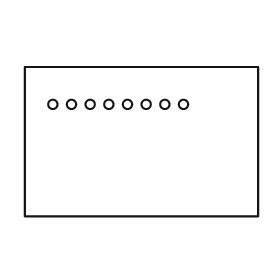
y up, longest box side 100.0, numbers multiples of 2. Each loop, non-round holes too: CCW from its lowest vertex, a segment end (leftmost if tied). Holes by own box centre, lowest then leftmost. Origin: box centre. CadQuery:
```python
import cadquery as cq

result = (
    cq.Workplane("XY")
    .moveTo(-50.0, -32.0)
    .lineTo(50.0, -32.0)
    .lineTo(50.0, 32.0)
    .lineTo(-50.0, 32.0)
    .close()
    .moveTo(-38.0, 16.0)
    .circle(2.0)
    .moveTo(-30.0, 16.0)
    .circle(2.0)
    .moveTo(-22.0, 16.0)
    .circle(2.0)
    .moveTo(-14.0, 16.0)
    .circle(2.0)
    .moveTo(-6.0, 16.0)
    .circle(2.0)
    .moveTo(2.0, 16.0)
    .circle(2.0)
    .moveTo(10.0, 16.0)
    .circle(2.0)
    .moveTo(18.0, 16.0)
    .circle(2.0)
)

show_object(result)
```